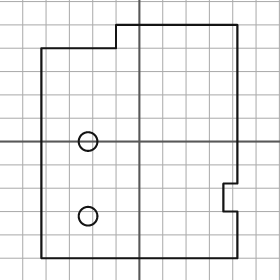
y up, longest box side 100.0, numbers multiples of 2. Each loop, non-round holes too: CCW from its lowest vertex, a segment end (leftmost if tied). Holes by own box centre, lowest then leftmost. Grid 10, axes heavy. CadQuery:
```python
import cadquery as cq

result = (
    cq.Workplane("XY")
    .moveTo(-42.0, -50.0)
    .lineTo(42.0, -50.0)
    .lineTo(42.0, -30.0)
    .lineTo(36.0, -30.0)
    .lineTo(36.0, -18.0)
    .lineTo(42.0, -18.0)
    .lineTo(42.0, 50.0)
    .lineTo(-10.0, 50.0)
    .lineTo(-10.0, 40.0)
    .lineTo(-42.0, 40.0)
    .close()
    .moveTo(-22.0, -32.0)
    .circle(4.0)
    .moveTo(-22.0, 0.0)
    .circle(4.0)
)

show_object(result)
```